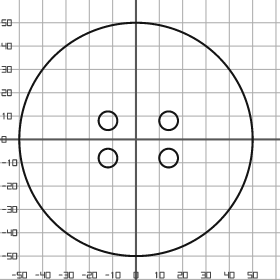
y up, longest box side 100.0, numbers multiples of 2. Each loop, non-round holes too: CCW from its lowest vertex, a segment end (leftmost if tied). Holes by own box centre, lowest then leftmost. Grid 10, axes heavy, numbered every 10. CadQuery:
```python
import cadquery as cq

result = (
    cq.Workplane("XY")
    .moveTo(0.0, 0.0)
    .circle(50.0)
    .moveTo(-12.0, -8.0)
    .circle(4.0)
    .moveTo(14.0, -8.0)
    .circle(4.0)
    .moveTo(-12.0, 8.0)
    .circle(4.0)
    .moveTo(14.0, 8.0)
    .circle(4.0)
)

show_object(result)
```